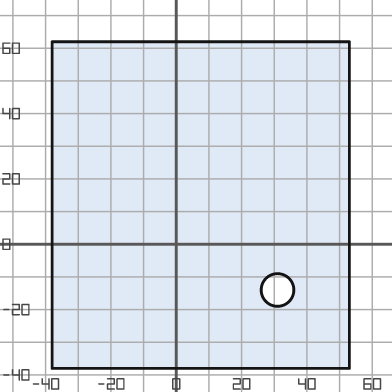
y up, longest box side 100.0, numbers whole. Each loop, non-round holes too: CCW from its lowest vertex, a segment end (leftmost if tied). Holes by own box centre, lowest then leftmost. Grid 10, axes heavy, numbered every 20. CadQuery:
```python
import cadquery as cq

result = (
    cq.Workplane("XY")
    .moveTo(-38.0, -38.0)
    .lineTo(53.0, -38.0)
    .lineTo(53.0, 62.0)
    .lineTo(-38.0, 62.0)
    .close()
    .moveTo(31.0, -14.0)
    .circle(5.0)
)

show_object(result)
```